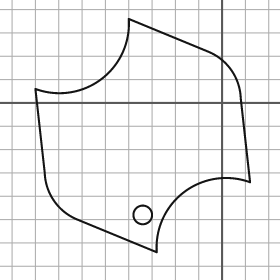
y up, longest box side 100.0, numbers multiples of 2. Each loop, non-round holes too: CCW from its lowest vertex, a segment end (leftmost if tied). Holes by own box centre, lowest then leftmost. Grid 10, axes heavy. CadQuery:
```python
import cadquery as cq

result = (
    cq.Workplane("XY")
    .moveTo(-28.0, -64.0)
    .threePointArc((-16.0, -38.0), (12.0, -34.0))
    .lineTo(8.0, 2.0)
    .threePointArc((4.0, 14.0), (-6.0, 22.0))
    .lineTo(-40.0, 36.0)
    .threePointArc((-52.0, 10.0), (-80.0, 6.0))
    .lineTo(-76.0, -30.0)
    .threePointArc((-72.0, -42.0), (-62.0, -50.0))
    .close()
    .moveTo(-34.0, -48.0)
    .circle(4.0)
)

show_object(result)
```